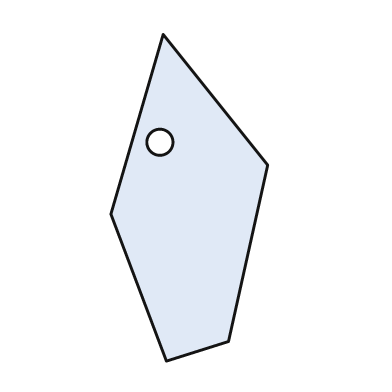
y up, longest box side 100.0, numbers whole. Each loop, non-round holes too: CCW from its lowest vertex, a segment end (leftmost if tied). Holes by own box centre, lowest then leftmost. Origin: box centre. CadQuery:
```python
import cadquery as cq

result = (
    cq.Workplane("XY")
    .moveTo(-7.0, -50.0)
    .lineTo(12.0, -44.0)
    .lineTo(24.0, 10.0)
    .lineTo(-8.0, 50.0)
    .lineTo(-24.0, -5.0)
    .close()
    .moveTo(-9.0, 17.0)
    .circle(4.0)
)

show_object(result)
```